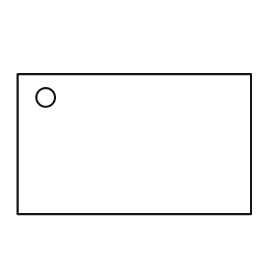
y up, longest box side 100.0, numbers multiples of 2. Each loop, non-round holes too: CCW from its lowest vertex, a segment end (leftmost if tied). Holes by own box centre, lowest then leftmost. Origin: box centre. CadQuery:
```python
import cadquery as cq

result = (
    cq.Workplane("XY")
    .moveTo(-50.0, -30.0)
    .lineTo(50.0, -30.0)
    .lineTo(50.0, 30.0)
    .lineTo(-50.0, 30.0)
    .close()
    .moveTo(-38.0, 20.0)
    .circle(4.0)
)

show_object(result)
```